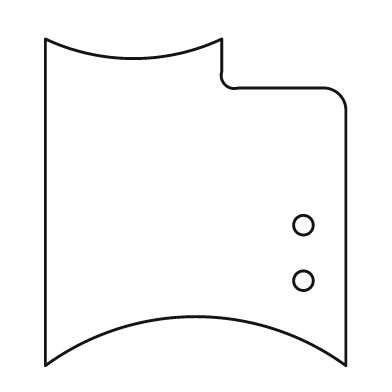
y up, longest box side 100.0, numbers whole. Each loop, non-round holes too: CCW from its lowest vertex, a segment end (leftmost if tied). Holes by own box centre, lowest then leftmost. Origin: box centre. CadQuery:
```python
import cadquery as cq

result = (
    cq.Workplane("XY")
    .moveTo(-46.0, -50.0)
    .threePointArc((0.0, -35.0), (46.0, -50.0))
    .lineTo(46.0, 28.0)
    .threePointArc((44.0, 33.0), (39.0, 35.0))
    .lineTo(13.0, 35.0)
    .threePointArc((9.0, 36.0), (8.0, 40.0))
    .lineTo(8.0, 50.0)
    .threePointArc((-19.0, 44.0), (-46.0, 50.0))
    .close()
    .moveTo(33.0, -24.0)
    .circle(3.0)
    .moveTo(33.0, -7.0)
    .circle(3.0)
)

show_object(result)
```